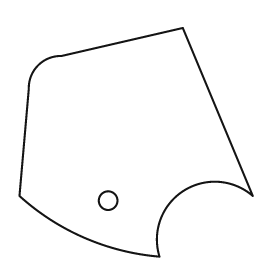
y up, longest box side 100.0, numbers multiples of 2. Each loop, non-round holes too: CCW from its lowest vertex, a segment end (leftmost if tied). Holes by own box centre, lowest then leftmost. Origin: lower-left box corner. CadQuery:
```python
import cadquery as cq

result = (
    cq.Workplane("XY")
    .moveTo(60.0, 0.0)
    .threePointArc((70.0, 28.0), (100.0, 26.0))
    .lineTo(70.0, 98.0)
    .lineTo(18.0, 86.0)
    .threePointArc((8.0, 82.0), (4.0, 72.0))
    .lineTo(0.0, 26.0)
    .threePointArc((28.0, 8.0), (60.0, 0.0))
    .close()
    .moveTo(38.0, 24.0)
    .circle(4.0)
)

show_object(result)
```